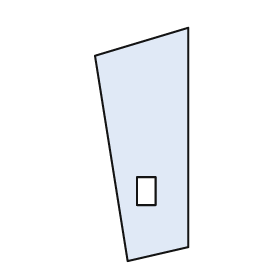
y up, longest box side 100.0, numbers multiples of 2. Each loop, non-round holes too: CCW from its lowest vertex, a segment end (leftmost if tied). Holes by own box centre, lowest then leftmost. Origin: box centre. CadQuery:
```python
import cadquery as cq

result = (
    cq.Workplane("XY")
    .moveTo(-6.0, -50.0)
    .lineTo(20.0, -44.0)
    .lineTo(20.0, 50.0)
    .lineTo(-20.0, 38.0)
    .close()
    .moveTo(-2.0, -26.0)
    .lineTo(6.0, -26.0)
    .lineTo(6.0, -14.0)
    .lineTo(-2.0, -14.0)
    .close()
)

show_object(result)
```